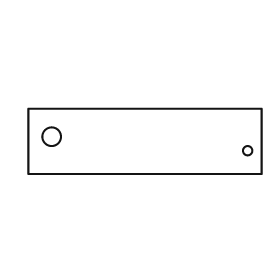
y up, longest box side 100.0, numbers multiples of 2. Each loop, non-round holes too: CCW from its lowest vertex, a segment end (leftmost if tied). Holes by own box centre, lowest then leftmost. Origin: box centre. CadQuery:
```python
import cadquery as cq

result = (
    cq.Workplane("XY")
    .moveTo(-50.0, -14.0)
    .lineTo(50.0, -14.0)
    .lineTo(50.0, 14.0)
    .lineTo(-50.0, 14.0)
    .close()
    .moveTo(44.0, -4.0)
    .circle(2.0)
    .moveTo(-40.0, 2.0)
    .circle(4.0)
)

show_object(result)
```